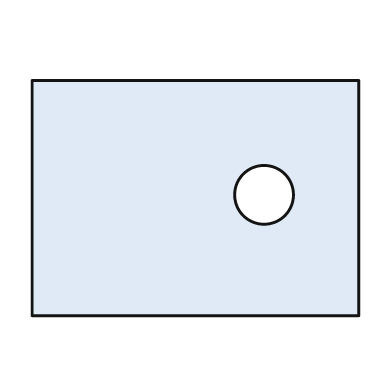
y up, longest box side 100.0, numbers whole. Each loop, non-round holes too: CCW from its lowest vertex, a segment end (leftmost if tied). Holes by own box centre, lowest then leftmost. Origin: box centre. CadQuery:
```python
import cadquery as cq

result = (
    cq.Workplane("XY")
    .moveTo(-50.0, -36.0)
    .lineTo(50.0, -36.0)
    .lineTo(50.0, 36.0)
    .lineTo(-50.0, 36.0)
    .close()
    .moveTo(21.0, 1.0)
    .circle(9.0)
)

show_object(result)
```